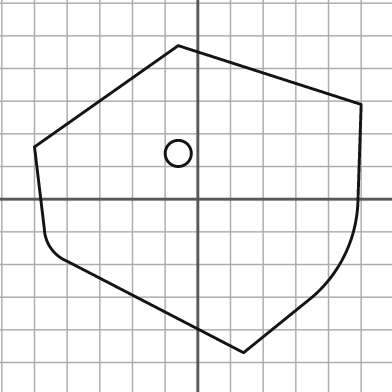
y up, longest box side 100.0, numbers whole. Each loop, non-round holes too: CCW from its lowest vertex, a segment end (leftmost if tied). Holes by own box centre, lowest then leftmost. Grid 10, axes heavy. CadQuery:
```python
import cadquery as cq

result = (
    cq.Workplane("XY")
    .moveTo(14.0, -47.0)
    .lineTo(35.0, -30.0)
    .threePointArc((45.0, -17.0), (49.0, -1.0))
    .lineTo(50.0, 29.0)
    .lineTo(-6.0, 47.0)
    .lineTo(-50.0, 16.0)
    .lineTo(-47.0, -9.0)
    .threePointArc((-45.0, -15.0), (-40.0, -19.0))
    .close()
    .moveTo(-6.0, 14.0)
    .circle(4.0)
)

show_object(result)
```